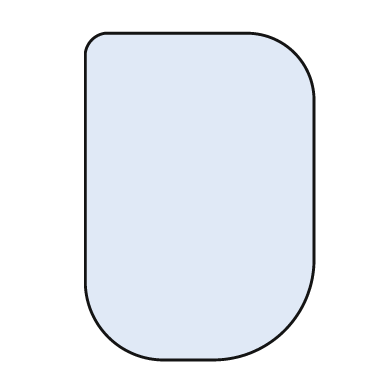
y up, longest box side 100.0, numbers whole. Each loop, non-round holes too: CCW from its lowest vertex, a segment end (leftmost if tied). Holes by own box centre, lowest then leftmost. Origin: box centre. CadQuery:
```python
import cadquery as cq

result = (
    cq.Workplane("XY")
    .moveTo(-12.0, -50.0)
    .lineTo(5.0, -50.0)
    .threePointArc((26.0, -41.0), (35.0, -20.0))
    .lineTo(35.0, 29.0)
    .threePointArc((29.0, 44.0), (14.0, 50.0))
    .lineTo(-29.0, 50.0)
    .threePointArc((-33.0, 48.0), (-35.0, 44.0))
    .lineTo(-35.0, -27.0)
    .threePointArc((-28.0, -43.0), (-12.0, -50.0))
    .close()
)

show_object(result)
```